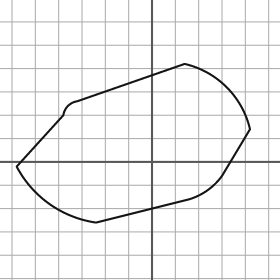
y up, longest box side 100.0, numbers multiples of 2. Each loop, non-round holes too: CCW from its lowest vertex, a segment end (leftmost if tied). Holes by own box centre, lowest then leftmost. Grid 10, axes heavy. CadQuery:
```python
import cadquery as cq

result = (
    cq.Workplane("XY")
    .moveTo(-24.0, -26.0)
    .lineTo(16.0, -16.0)
    .threePointArc((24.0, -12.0), (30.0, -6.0))
    .lineTo(42.0, 14.0)
    .threePointArc((32.0, 32.0), (14.0, 42.0))
    .lineTo(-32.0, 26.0)
    .threePointArc((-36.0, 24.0), (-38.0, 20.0))
    .lineTo(-58.0, -2.0)
    .threePointArc((-44.0, -18.0), (-24.0, -26.0))
    .close()
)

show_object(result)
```